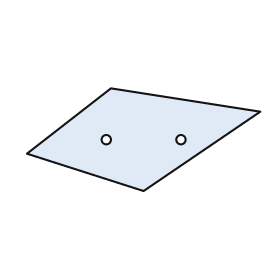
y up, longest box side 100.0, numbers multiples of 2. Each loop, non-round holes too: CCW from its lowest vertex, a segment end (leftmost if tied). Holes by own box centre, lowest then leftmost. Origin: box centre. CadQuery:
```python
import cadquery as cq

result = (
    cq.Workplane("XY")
    .moveTo(0.0, -22.0)
    .lineTo(50.0, 12.0)
    .lineTo(-14.0, 22.0)
    .lineTo(-50.0, -6.0)
    .close()
    .moveTo(-16.0, 0.0)
    .circle(2.0)
    .moveTo(16.0, 0.0)
    .circle(2.0)
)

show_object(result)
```